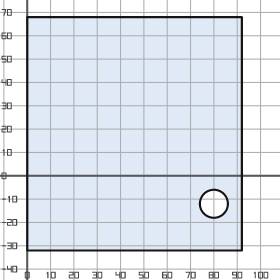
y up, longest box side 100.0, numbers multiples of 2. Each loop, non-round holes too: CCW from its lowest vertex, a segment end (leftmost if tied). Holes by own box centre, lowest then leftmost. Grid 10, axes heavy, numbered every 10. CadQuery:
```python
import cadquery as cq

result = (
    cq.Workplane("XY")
    .moveTo(0.0, -32.0)
    .lineTo(92.0, -32.0)
    .lineTo(92.0, 68.0)
    .lineTo(0.0, 68.0)
    .close()
    .moveTo(80.0, -12.0)
    .circle(6.0)
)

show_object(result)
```